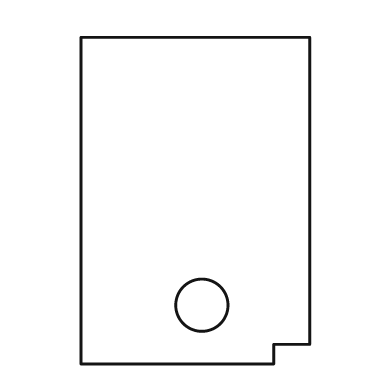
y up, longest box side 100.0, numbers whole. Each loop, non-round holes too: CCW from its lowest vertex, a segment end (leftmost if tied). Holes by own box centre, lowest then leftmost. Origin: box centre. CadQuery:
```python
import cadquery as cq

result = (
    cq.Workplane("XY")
    .moveTo(-35.0, -50.0)
    .lineTo(24.0, -50.0)
    .lineTo(24.0, -44.0)
    .lineTo(35.0, -44.0)
    .lineTo(35.0, 50.0)
    .lineTo(-35.0, 50.0)
    .close()
    .moveTo(2.0, -32.0)
    .circle(8.0)
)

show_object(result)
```